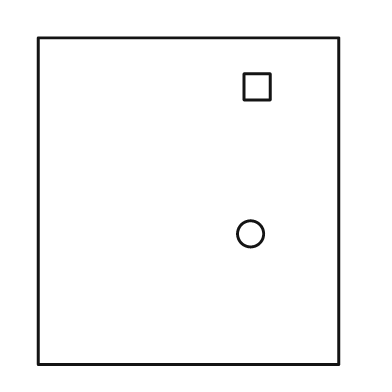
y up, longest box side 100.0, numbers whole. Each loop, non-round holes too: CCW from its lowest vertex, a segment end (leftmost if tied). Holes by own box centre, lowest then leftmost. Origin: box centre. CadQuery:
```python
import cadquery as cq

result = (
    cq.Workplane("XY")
    .moveTo(-46.0, -50.0)
    .lineTo(46.0, -50.0)
    .lineTo(46.0, 50.0)
    .lineTo(-46.0, 50.0)
    .close()
    .moveTo(19.0, -10.0)
    .circle(4.0)
    .moveTo(17.0, 31.0)
    .lineTo(25.0, 31.0)
    .lineTo(25.0, 39.0)
    .lineTo(17.0, 39.0)
    .close()
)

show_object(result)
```